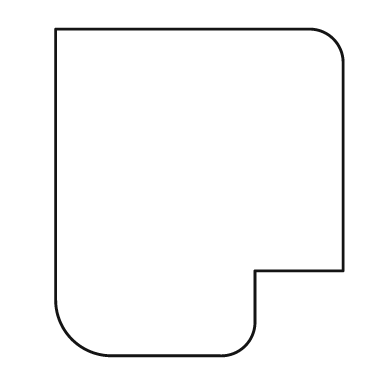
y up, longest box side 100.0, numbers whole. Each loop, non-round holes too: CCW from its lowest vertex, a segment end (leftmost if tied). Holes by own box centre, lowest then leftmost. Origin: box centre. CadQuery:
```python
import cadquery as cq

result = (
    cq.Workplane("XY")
    .moveTo(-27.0, -50.0)
    .lineTo(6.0, -50.0)
    .threePointArc((14.0, -47.0), (17.0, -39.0))
    .lineTo(17.0, -24.0)
    .lineTo(44.0, -24.0)
    .lineTo(44.0, 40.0)
    .threePointArc((41.0, 47.0), (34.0, 50.0))
    .lineTo(-44.0, 50.0)
    .lineTo(-44.0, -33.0)
    .threePointArc((-39.0, -45.0), (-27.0, -50.0))
    .close()
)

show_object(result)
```